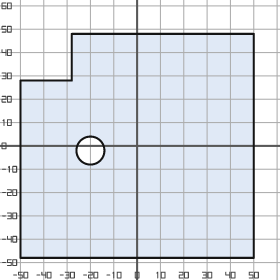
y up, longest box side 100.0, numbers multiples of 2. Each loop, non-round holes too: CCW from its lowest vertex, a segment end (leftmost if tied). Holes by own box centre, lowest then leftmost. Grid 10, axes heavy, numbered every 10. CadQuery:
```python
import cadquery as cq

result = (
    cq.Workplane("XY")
    .moveTo(-50.0, -48.0)
    .lineTo(50.0, -48.0)
    .lineTo(50.0, 48.0)
    .lineTo(-28.0, 48.0)
    .lineTo(-28.0, 28.0)
    .lineTo(-50.0, 28.0)
    .close()
    .moveTo(-20.0, -2.0)
    .circle(6.0)
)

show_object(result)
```